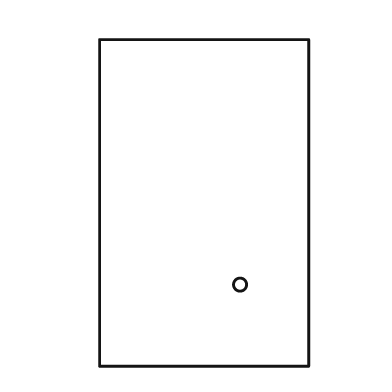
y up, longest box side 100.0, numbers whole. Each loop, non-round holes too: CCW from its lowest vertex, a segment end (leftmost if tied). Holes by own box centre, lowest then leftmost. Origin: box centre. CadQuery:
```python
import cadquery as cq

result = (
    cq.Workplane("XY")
    .moveTo(-32.0, -50.0)
    .lineTo(32.0, -50.0)
    .lineTo(32.0, 50.0)
    .lineTo(-32.0, 50.0)
    .close()
    .moveTo(11.0, -25.0)
    .circle(2.0)
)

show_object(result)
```